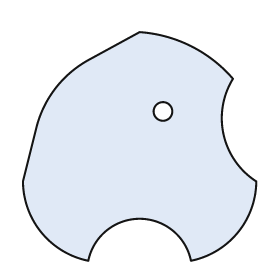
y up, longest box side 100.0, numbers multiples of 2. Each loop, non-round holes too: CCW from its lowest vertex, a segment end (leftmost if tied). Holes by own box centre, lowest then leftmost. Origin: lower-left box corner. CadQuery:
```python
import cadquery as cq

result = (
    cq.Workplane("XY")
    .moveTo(28.0, 0.0)
    .threePointArc((50.0, 18.0), (72.0, 0.0))
    .threePointArc((92.0, 12.0), (100.0, 34.0))
    .threePointArc((86.0, 54.0), (90.0, 78.0))
    .threePointArc((72.0, 92.0), (50.0, 98.0))
    .lineTo(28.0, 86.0)
    .threePointArc((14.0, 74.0), (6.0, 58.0))
    .lineTo(0.0, 34.0)
    .threePointArc((8.0, 12.0), (28.0, 0.0))
    .close()
    .moveTo(60.0, 64.0)
    .circle(4.0)
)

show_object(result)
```